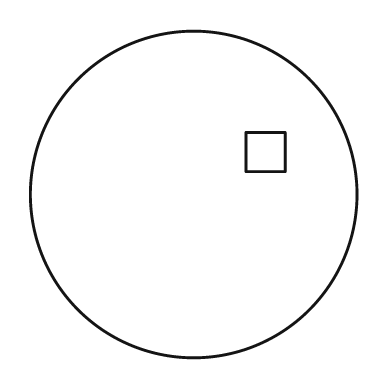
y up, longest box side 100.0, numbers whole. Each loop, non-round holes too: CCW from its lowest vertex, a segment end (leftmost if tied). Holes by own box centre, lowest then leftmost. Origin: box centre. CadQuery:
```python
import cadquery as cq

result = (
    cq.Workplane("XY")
    .moveTo(0.0, 0.0)
    .circle(50.0)
    .moveTo(16.0, 7.0)
    .lineTo(28.0, 7.0)
    .lineTo(28.0, 19.0)
    .lineTo(16.0, 19.0)
    .close()
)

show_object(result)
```